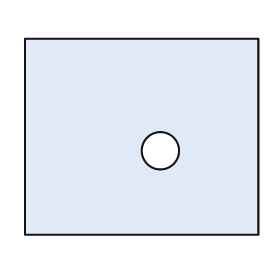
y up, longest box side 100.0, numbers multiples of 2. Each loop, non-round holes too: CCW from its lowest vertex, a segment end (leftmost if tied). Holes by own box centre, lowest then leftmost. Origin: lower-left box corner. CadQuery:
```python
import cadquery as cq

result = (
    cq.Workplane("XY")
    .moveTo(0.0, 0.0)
    .lineTo(100.0, 0.0)
    .lineTo(100.0, 84.0)
    .lineTo(0.0, 84.0)
    .close()
    .moveTo(58.0, 36.0)
    .circle(8.0)
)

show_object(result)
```